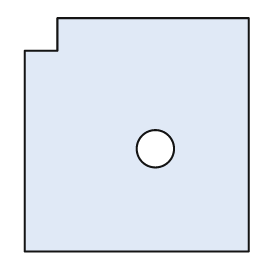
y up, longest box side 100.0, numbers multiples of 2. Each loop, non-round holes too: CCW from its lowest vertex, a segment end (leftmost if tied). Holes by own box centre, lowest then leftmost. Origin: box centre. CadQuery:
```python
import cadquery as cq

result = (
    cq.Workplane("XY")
    .moveTo(-48.0, -50.0)
    .lineTo(48.0, -50.0)
    .lineTo(48.0, 50.0)
    .lineTo(-34.0, 50.0)
    .lineTo(-34.0, 36.0)
    .lineTo(-48.0, 36.0)
    .close()
    .moveTo(8.0, -6.0)
    .circle(8.0)
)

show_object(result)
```